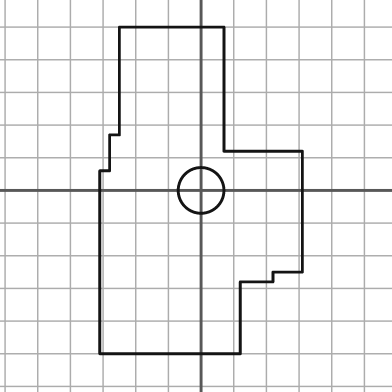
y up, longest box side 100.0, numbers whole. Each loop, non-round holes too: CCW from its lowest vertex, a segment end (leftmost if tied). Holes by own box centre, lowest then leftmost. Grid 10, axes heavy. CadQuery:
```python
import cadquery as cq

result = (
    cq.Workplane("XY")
    .moveTo(-31.0, -50.0)
    .lineTo(12.0, -50.0)
    .lineTo(12.0, -28.0)
    .lineTo(22.0, -28.0)
    .lineTo(22.0, -25.0)
    .lineTo(31.0, -25.0)
    .lineTo(31.0, 12.0)
    .lineTo(7.0, 12.0)
    .lineTo(7.0, 50.0)
    .lineTo(-25.0, 50.0)
    .lineTo(-25.0, 17.0)
    .lineTo(-28.0, 17.0)
    .lineTo(-28.0, 6.0)
    .lineTo(-31.0, 6.0)
    .close()
    .moveTo(0.0, 0.0)
    .circle(7.0)
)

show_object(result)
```